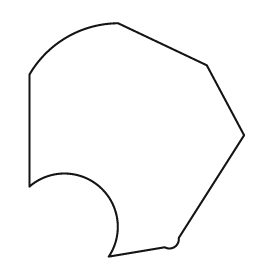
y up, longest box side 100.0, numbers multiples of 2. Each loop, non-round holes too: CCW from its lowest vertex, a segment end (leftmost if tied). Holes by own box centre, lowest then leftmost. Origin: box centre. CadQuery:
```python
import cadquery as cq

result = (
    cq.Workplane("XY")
    .moveTo(-12.0, -50.0)
    .lineTo(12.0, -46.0)
    .threePointArc((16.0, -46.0), (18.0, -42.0))
    .lineTo(46.0, 2.0)
    .lineTo(30.0, 32.0)
    .lineTo(-8.0, 50.0)
    .threePointArc((-30.0, 44.0), (-46.0, 28.0))
    .lineTo(-46.0, -20.0)
    .threePointArc((-16.0, -20.0), (-12.0, -50.0))
    .close()
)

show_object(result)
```